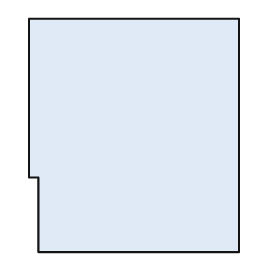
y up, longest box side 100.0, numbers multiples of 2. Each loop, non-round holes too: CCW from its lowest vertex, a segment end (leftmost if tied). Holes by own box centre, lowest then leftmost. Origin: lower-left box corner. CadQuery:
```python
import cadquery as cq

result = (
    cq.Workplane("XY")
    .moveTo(4.0, 0.0)
    .lineTo(90.0, 0.0)
    .lineTo(90.0, 100.0)
    .lineTo(0.0, 100.0)
    .lineTo(0.0, 32.0)
    .lineTo(4.0, 32.0)
    .close()
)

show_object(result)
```